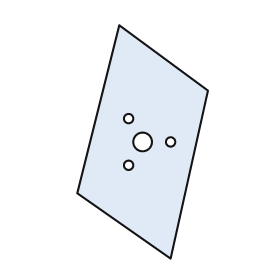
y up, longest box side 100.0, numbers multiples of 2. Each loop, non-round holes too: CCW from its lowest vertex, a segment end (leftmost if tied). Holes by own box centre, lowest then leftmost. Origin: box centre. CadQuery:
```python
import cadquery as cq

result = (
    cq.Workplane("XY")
    .moveTo(12.0, -50.0)
    .lineTo(28.0, 22.0)
    .lineTo(-10.0, 50.0)
    .lineTo(-28.0, -22.0)
    .close()
    .moveTo(-6.0, -10.0)
    .circle(2.0)
    .moveTo(0.0, 0.0)
    .circle(4.0)
    .moveTo(12.0, 0.0)
    .circle(2.0)
    .moveTo(-6.0, 10.0)
    .circle(2.0)
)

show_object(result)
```